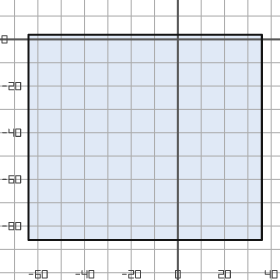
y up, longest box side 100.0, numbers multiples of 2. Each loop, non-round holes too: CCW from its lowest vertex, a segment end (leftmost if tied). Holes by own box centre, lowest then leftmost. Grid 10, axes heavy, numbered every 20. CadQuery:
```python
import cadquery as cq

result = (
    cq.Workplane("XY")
    .moveTo(-64.0, -86.0)
    .lineTo(36.0, -86.0)
    .lineTo(36.0, 2.0)
    .lineTo(-64.0, 2.0)
    .close()
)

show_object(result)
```